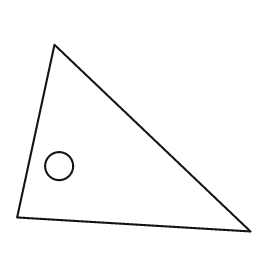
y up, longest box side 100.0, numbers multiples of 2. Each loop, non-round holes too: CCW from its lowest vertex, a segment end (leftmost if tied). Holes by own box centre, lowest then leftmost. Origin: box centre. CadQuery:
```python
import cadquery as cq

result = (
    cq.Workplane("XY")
    .moveTo(50.0, -40.0)
    .lineTo(-34.0, 40.0)
    .lineTo(-50.0, -34.0)
    .close()
    .moveTo(-32.0, -12.0)
    .circle(6.0)
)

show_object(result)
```